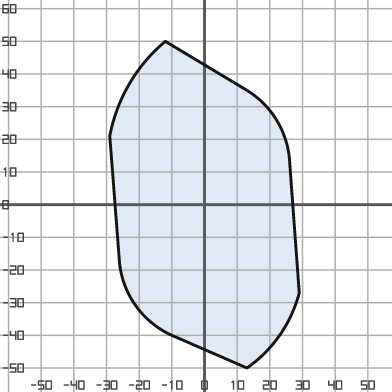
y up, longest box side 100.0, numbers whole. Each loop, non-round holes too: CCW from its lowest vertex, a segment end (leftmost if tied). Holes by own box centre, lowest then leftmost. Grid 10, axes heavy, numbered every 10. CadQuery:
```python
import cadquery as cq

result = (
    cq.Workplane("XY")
    .moveTo(13.0, -50.0)
    .threePointArc((23.0, -40.0), (29.0, -27.0))
    .lineTo(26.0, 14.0)
    .threePointArc((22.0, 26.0), (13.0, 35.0))
    .lineTo(-12.0, 50.0)
    .threePointArc((-23.0, 37.0), (-29.0, 21.0))
    .lineTo(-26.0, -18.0)
    .threePointArc((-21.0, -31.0), (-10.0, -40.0))
    .close()
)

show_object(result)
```